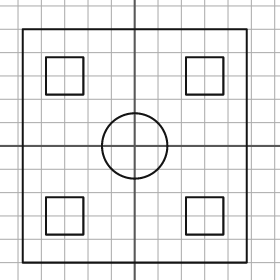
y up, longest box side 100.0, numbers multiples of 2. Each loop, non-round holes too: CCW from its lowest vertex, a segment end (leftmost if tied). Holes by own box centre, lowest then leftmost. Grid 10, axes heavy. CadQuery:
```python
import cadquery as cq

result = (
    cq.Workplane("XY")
    .moveTo(-48.0, -50.0)
    .lineTo(48.0, -50.0)
    .lineTo(48.0, 50.0)
    .lineTo(-48.0, 50.0)
    .close()
    .moveTo(-38.0, -38.0)
    .lineTo(-22.0, -38.0)
    .lineTo(-22.0, -22.0)
    .lineTo(-38.0, -22.0)
    .close()
    .moveTo(22.0, -38.0)
    .lineTo(38.0, -38.0)
    .lineTo(38.0, -22.0)
    .lineTo(22.0, -22.0)
    .close()
    .moveTo(0.0, 0.0)
    .circle(14.0)
    .moveTo(-38.0, 22.0)
    .lineTo(-22.0, 22.0)
    .lineTo(-22.0, 38.0)
    .lineTo(-38.0, 38.0)
    .close()
    .moveTo(22.0, 22.0)
    .lineTo(38.0, 22.0)
    .lineTo(38.0, 38.0)
    .lineTo(22.0, 38.0)
    .close()
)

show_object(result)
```